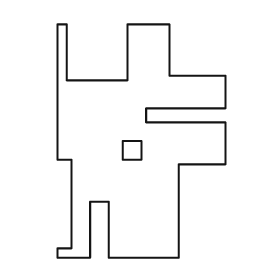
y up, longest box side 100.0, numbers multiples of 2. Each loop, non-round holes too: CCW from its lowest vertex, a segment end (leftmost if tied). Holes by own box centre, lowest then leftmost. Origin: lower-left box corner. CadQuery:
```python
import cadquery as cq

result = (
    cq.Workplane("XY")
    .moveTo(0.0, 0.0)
    .lineTo(14.0, 0.0)
    .lineTo(14.0, 24.0)
    .lineTo(22.0, 24.0)
    .lineTo(22.0, 0.0)
    .lineTo(52.0, 0.0)
    .lineTo(52.0, 40.0)
    .lineTo(72.0, 40.0)
    .lineTo(72.0, 58.0)
    .lineTo(38.0, 58.0)
    .lineTo(38.0, 64.0)
    .lineTo(72.0, 64.0)
    .lineTo(72.0, 78.0)
    .lineTo(48.0, 78.0)
    .lineTo(48.0, 100.0)
    .lineTo(30.0, 100.0)
    .lineTo(30.0, 76.0)
    .lineTo(4.0, 76.0)
    .lineTo(4.0, 100.0)
    .lineTo(0.0, 100.0)
    .lineTo(0.0, 42.0)
    .lineTo(6.0, 42.0)
    .lineTo(6.0, 4.0)
    .lineTo(0.0, 4.0)
    .close()
    .moveTo(28.0, 42.0)
    .lineTo(36.0, 42.0)
    .lineTo(36.0, 50.0)
    .lineTo(28.0, 50.0)
    .close()
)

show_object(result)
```